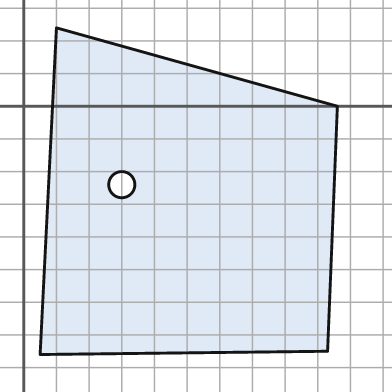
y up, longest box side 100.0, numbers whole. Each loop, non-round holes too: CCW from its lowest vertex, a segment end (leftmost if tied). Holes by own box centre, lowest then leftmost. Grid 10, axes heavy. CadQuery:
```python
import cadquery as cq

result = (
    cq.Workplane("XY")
    .moveTo(5.0, -76.0)
    .lineTo(93.0, -75.0)
    .lineTo(96.0, 0.0)
    .lineTo(10.0, 24.0)
    .close()
    .moveTo(30.0, -24.0)
    .circle(4.0)
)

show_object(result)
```